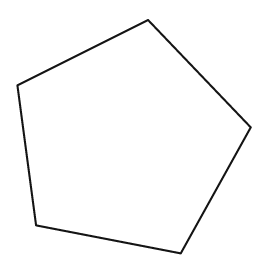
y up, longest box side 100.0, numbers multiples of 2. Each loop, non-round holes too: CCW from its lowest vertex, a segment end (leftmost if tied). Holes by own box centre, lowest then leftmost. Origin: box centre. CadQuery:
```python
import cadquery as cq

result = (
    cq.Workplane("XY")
    .moveTo(20.0, -50.0)
    .lineTo(50.0, 4.0)
    .lineTo(6.0, 50.0)
    .lineTo(-50.0, 22.0)
    .lineTo(-42.0, -38.0)
    .close()
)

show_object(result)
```